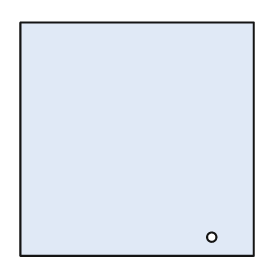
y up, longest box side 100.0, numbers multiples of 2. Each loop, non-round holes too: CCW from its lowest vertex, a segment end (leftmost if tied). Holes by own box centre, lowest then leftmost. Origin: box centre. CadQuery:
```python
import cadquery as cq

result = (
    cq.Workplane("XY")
    .moveTo(-50.0, -50.0)
    .lineTo(50.0, -50.0)
    .lineTo(50.0, 50.0)
    .lineTo(-50.0, 50.0)
    .close()
    .moveTo(32.0, -42.0)
    .circle(2.0)
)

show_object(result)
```